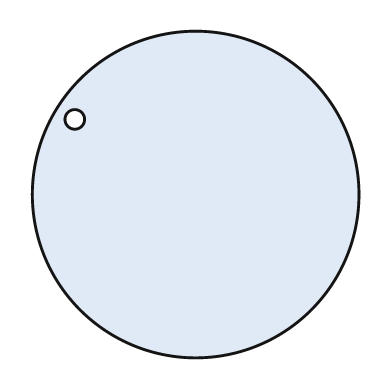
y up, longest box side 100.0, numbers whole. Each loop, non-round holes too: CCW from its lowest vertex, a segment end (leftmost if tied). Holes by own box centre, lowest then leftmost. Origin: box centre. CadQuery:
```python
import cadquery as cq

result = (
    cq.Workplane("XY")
    .moveTo(0.0, 0.0)
    .circle(50.0)
    .moveTo(-37.0, 23.0)
    .circle(3.0)
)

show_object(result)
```